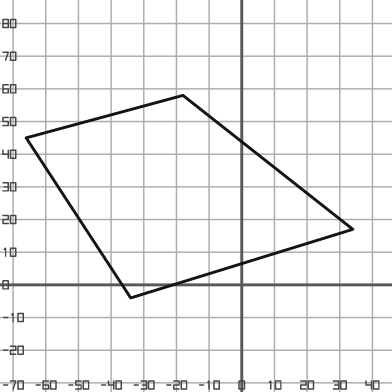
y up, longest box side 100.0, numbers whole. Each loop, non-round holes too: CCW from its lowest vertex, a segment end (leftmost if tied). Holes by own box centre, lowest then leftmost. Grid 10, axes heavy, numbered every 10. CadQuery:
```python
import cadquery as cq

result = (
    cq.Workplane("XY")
    .moveTo(-34.0, -4.0)
    .lineTo(34.0, 17.0)
    .lineTo(-18.0, 58.0)
    .lineTo(-66.0, 45.0)
    .close()
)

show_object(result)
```